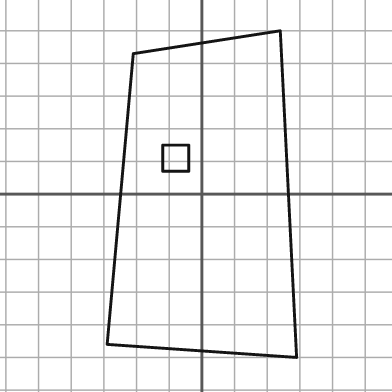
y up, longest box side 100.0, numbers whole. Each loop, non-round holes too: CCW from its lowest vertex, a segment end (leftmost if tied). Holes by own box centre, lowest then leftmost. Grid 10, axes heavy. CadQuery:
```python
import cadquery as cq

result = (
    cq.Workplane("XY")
    .moveTo(29.0, -50.0)
    .lineTo(24.0, 50.0)
    .lineTo(-21.0, 43.0)
    .lineTo(-29.0, -46.0)
    .close()
    .moveTo(-12.0, 7.0)
    .lineTo(-4.0, 7.0)
    .lineTo(-4.0, 15.0)
    .lineTo(-12.0, 15.0)
    .close()
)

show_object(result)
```